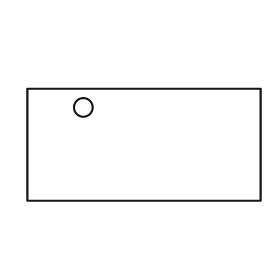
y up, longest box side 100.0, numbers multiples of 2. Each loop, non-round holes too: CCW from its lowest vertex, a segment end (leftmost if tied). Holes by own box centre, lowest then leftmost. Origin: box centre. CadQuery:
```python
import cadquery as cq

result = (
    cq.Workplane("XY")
    .moveTo(-50.0, -24.0)
    .lineTo(50.0, -24.0)
    .lineTo(50.0, 24.0)
    .lineTo(-50.0, 24.0)
    .close()
    .moveTo(-26.0, 16.0)
    .circle(4.0)
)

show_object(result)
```